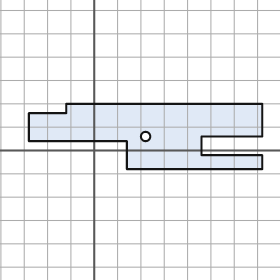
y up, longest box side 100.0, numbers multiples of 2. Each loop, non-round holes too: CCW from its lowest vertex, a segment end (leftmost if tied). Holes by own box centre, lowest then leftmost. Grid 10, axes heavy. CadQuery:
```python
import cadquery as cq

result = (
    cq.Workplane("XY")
    .moveTo(14.0, -8.0)
    .lineTo(72.0, -8.0)
    .lineTo(72.0, -2.0)
    .lineTo(46.0, -2.0)
    .lineTo(46.0, 6.0)
    .lineTo(72.0, 6.0)
    .lineTo(72.0, 20.0)
    .lineTo(-12.0, 20.0)
    .lineTo(-12.0, 16.0)
    .lineTo(-28.0, 16.0)
    .lineTo(-28.0, 4.0)
    .lineTo(14.0, 4.0)
    .close()
    .moveTo(22.0, 6.0)
    .circle(2.0)
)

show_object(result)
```